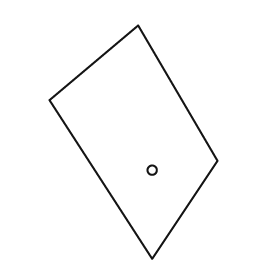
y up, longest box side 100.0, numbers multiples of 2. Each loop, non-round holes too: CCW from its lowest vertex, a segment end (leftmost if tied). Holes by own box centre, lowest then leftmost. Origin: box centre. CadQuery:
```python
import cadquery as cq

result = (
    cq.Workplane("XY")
    .moveTo(8.0, -50.0)
    .lineTo(36.0, -8.0)
    .lineTo(2.0, 50.0)
    .lineTo(-36.0, 18.0)
    .close()
    .moveTo(8.0, -12.0)
    .circle(2.0)
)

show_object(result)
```